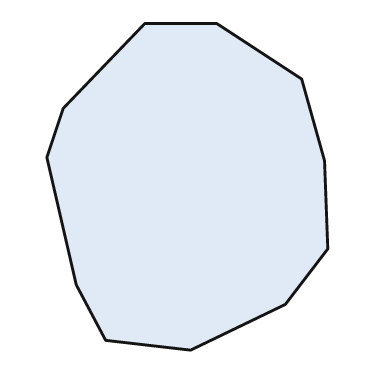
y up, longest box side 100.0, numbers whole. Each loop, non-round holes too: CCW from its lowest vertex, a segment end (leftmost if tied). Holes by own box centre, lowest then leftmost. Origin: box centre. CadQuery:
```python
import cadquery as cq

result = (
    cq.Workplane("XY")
    .moveTo(1.0, -50.0)
    .lineTo(30.0, -36.0)
    .lineTo(43.0, -19.0)
    .lineTo(42.0, 8.0)
    .lineTo(35.0, 33.0)
    .lineTo(9.0, 50.0)
    .lineTo(-13.0, 50.0)
    .lineTo(-38.0, 24.0)
    .lineTo(-43.0, 9.0)
    .lineTo(-34.0, -30.0)
    .lineTo(-25.0, -47.0)
    .close()
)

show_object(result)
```